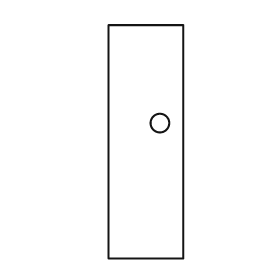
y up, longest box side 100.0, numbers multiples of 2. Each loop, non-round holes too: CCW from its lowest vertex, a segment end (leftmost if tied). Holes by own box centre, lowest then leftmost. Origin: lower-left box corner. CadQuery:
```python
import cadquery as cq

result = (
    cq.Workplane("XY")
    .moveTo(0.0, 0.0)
    .lineTo(32.0, 0.0)
    .lineTo(32.0, 100.0)
    .lineTo(0.0, 100.0)
    .close()
    .moveTo(22.0, 58.0)
    .circle(4.0)
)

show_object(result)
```